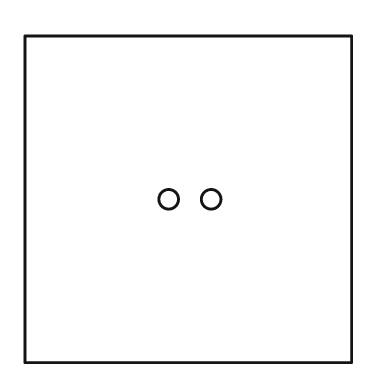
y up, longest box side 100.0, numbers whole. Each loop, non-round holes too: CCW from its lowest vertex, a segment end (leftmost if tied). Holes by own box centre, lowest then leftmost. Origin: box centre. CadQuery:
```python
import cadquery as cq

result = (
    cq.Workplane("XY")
    .moveTo(-50.0, -50.0)
    .lineTo(50.0, -50.0)
    .lineTo(50.0, 50.0)
    .lineTo(-50.0, 50.0)
    .close()
    .moveTo(-6.0, 0.0)
    .circle(3.0)
    .moveTo(7.0, 0.0)
    .circle(3.0)
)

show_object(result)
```